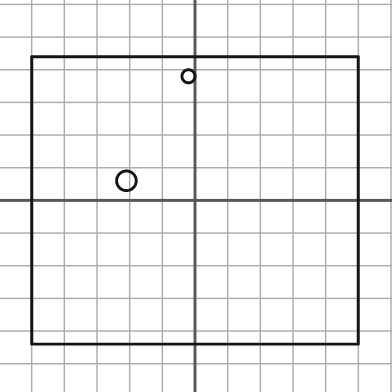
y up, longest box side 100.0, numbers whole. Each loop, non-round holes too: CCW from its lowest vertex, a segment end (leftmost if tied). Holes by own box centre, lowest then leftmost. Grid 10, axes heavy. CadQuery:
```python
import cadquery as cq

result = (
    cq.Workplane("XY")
    .moveTo(-50.0, -44.0)
    .lineTo(50.0, -44.0)
    .lineTo(50.0, 44.0)
    .lineTo(-50.0, 44.0)
    .close()
    .moveTo(-21.0, 6.0)
    .circle(3.0)
    .moveTo(-2.0, 38.0)
    .circle(2.0)
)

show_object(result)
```